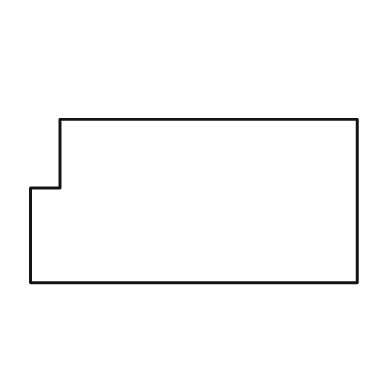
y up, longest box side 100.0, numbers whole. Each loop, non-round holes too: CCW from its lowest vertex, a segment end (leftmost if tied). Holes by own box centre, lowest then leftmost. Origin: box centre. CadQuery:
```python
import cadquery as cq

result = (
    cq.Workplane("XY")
    .moveTo(-50.0, -25.0)
    .lineTo(50.0, -25.0)
    .lineTo(50.0, 25.0)
    .lineTo(-41.0, 25.0)
    .lineTo(-41.0, 4.0)
    .lineTo(-50.0, 4.0)
    .close()
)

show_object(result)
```